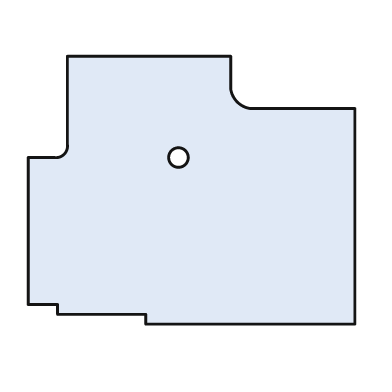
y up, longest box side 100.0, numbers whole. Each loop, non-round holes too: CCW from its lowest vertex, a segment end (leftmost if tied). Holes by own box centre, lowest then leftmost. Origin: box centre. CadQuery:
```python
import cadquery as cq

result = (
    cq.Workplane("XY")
    .moveTo(-14.0, -41.0)
    .lineTo(50.0, -41.0)
    .lineTo(50.0, 25.0)
    .lineTo(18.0, 25.0)
    .threePointArc((14.0, 27.0), (12.0, 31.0))
    .lineTo(12.0, 41.0)
    .lineTo(-38.0, 41.0)
    .lineTo(-38.0, 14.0)
    .threePointArc((-39.0, 11.0), (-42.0, 10.0))
    .lineTo(-50.0, 10.0)
    .lineTo(-50.0, -35.0)
    .lineTo(-41.0, -35.0)
    .lineTo(-41.0, -38.0)
    .lineTo(-14.0, -38.0)
    .close()
    .moveTo(-4.0, 10.0)
    .circle(3.0)
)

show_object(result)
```